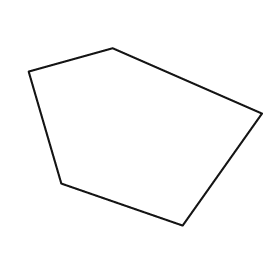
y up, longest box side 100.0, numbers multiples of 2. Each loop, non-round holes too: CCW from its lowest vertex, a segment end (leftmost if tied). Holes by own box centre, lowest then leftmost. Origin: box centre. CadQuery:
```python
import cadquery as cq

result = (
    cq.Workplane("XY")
    .moveTo(16.0, -38.0)
    .lineTo(50.0, 10.0)
    .lineTo(-14.0, 38.0)
    .lineTo(-50.0, 28.0)
    .lineTo(-36.0, -20.0)
    .close()
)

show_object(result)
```